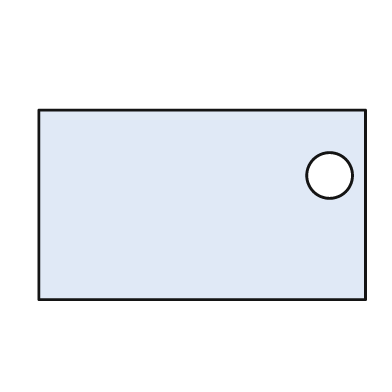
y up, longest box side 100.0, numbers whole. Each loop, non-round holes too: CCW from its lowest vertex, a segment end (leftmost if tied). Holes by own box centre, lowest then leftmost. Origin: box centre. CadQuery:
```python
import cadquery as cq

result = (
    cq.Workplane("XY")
    .moveTo(-50.0, -29.0)
    .lineTo(50.0, -29.0)
    .lineTo(50.0, 29.0)
    .lineTo(-50.0, 29.0)
    .close()
    .moveTo(39.0, 9.0)
    .circle(7.0)
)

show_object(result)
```